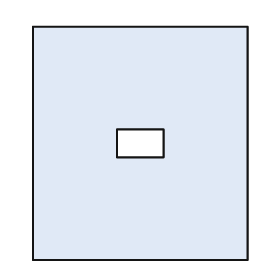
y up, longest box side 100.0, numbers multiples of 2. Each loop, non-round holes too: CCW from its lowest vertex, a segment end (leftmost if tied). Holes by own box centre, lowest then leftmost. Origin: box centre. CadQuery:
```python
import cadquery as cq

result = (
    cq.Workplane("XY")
    .moveTo(-46.0, -50.0)
    .lineTo(46.0, -50.0)
    .lineTo(46.0, 50.0)
    .lineTo(-46.0, 50.0)
    .close()
    .moveTo(-10.0, -6.0)
    .lineTo(10.0, -6.0)
    .lineTo(10.0, 6.0)
    .lineTo(-10.0, 6.0)
    .close()
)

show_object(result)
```